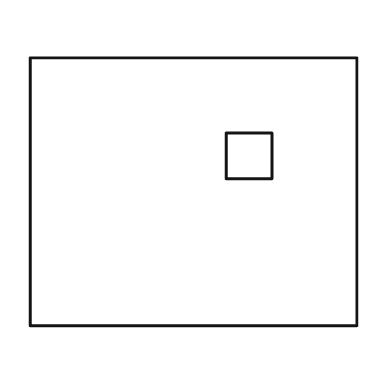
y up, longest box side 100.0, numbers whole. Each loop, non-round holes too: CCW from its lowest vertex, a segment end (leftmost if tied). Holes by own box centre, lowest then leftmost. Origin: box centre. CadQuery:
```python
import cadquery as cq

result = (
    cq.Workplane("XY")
    .moveTo(-50.0, -41.0)
    .lineTo(50.0, -41.0)
    .lineTo(50.0, 41.0)
    .lineTo(-50.0, 41.0)
    .close()
    .moveTo(10.0, 4.0)
    .lineTo(24.0, 4.0)
    .lineTo(24.0, 18.0)
    .lineTo(10.0, 18.0)
    .close()
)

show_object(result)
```